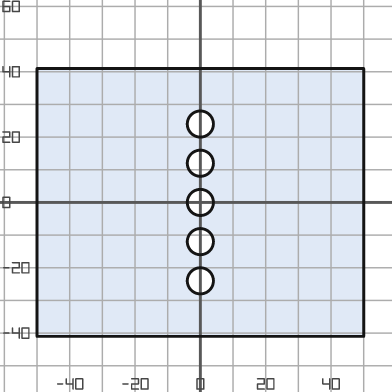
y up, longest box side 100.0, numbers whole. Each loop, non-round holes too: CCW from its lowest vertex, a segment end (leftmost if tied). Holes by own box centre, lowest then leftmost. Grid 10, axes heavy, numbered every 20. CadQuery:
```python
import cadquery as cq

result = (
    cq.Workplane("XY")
    .moveTo(-50.0, -41.0)
    .lineTo(50.0, -41.0)
    .lineTo(50.0, 41.0)
    .lineTo(-50.0, 41.0)
    .close()
    .moveTo(0.0, -24.0)
    .circle(4.0)
    .moveTo(0.0, -12.0)
    .circle(4.0)
    .moveTo(0.0, 0.0)
    .circle(4.0)
    .moveTo(0.0, 12.0)
    .circle(4.0)
    .moveTo(0.0, 24.0)
    .circle(4.0)
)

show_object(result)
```